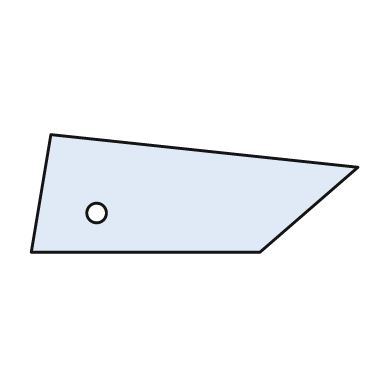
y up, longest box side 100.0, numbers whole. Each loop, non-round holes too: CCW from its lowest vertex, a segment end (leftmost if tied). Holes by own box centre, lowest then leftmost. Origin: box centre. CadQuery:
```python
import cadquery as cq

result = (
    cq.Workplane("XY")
    .moveTo(-50.0, -18.0)
    .lineTo(20.0, -18.0)
    .lineTo(50.0, 8.0)
    .lineTo(-44.0, 18.0)
    .close()
    .moveTo(-30.0, -6.0)
    .circle(3.0)
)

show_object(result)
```